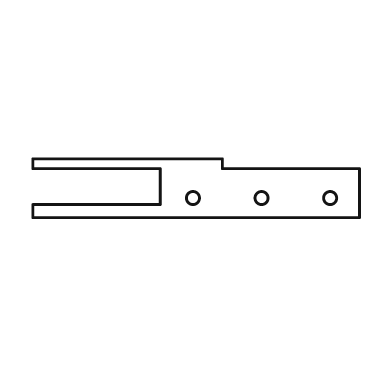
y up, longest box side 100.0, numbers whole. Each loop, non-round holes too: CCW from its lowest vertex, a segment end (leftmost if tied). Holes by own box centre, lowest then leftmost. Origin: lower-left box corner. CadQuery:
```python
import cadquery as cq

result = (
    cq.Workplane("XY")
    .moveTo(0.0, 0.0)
    .lineTo(100.0, 0.0)
    .lineTo(100.0, 15.0)
    .lineTo(58.0, 15.0)
    .lineTo(58.0, 18.0)
    .lineTo(0.0, 18.0)
    .lineTo(0.0, 15.0)
    .lineTo(39.0, 15.0)
    .lineTo(39.0, 4.0)
    .lineTo(0.0, 4.0)
    .close()
    .moveTo(49.0, 6.0)
    .circle(2.0)
    .moveTo(70.0, 6.0)
    .circle(2.0)
    .moveTo(91.0, 6.0)
    .circle(2.0)
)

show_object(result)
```